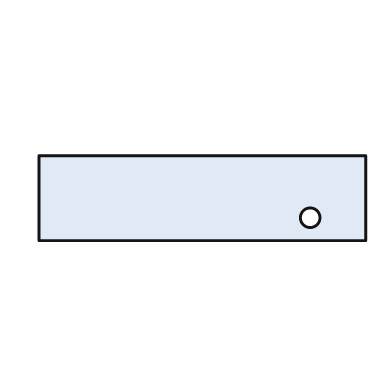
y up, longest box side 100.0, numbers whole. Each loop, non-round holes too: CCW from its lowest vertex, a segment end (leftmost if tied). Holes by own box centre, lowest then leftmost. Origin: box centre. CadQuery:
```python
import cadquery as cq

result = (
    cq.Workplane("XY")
    .moveTo(-50.0, -13.0)
    .lineTo(50.0, -13.0)
    .lineTo(50.0, 13.0)
    .lineTo(-50.0, 13.0)
    .close()
    .moveTo(33.0, -6.0)
    .circle(3.0)
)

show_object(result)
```